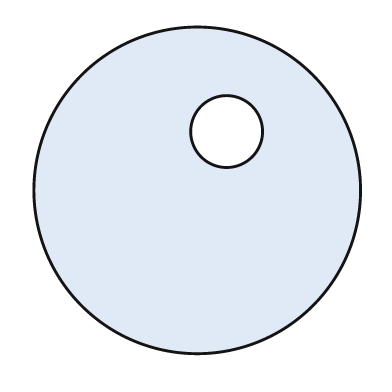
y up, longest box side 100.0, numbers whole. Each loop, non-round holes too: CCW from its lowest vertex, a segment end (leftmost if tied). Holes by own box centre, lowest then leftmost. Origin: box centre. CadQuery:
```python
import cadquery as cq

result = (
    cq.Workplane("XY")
    .moveTo(0.0, 0.0)
    .circle(50.0)
    .moveTo(9.0, 18.0)
    .circle(11.0)
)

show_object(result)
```